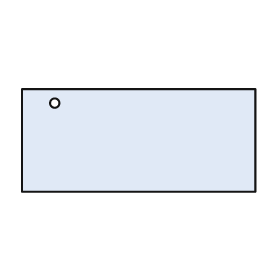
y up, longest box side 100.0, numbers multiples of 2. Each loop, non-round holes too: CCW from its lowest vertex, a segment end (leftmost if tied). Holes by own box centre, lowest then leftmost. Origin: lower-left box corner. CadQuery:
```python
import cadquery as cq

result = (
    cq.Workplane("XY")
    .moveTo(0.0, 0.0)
    .lineTo(100.0, 0.0)
    .lineTo(100.0, 44.0)
    .lineTo(0.0, 44.0)
    .close()
    .moveTo(14.0, 38.0)
    .circle(2.0)
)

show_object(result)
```